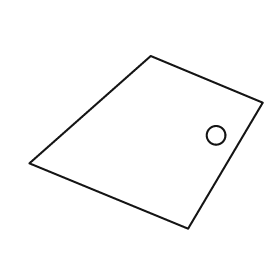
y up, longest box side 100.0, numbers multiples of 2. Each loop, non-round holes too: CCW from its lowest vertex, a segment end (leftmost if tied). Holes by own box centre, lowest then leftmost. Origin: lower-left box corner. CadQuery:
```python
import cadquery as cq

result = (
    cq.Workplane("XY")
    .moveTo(68.0, 0.0)
    .lineTo(100.0, 54.0)
    .lineTo(52.0, 74.0)
    .lineTo(0.0, 28.0)
    .close()
    .moveTo(80.0, 40.0)
    .circle(4.0)
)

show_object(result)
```